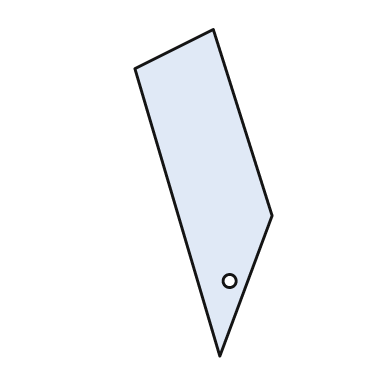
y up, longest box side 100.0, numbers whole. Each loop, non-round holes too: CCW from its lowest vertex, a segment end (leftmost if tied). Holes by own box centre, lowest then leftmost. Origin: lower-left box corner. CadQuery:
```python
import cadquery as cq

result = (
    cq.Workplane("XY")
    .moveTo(26.0, 0.0)
    .lineTo(42.0, 43.0)
    .lineTo(24.0, 100.0)
    .lineTo(0.0, 88.0)
    .close()
    .moveTo(29.0, 23.0)
    .circle(2.0)
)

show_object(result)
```